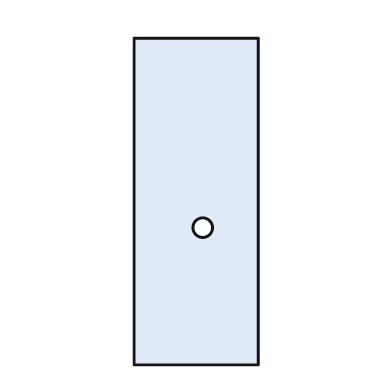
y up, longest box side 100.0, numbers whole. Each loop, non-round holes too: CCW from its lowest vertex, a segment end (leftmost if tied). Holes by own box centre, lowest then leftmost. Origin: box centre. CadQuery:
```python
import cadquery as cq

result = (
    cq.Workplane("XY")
    .moveTo(-19.0, -50.0)
    .lineTo(19.0, -50.0)
    .lineTo(19.0, 50.0)
    .lineTo(-19.0, 50.0)
    .close()
    .moveTo(2.0, -8.0)
    .circle(3.0)
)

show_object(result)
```